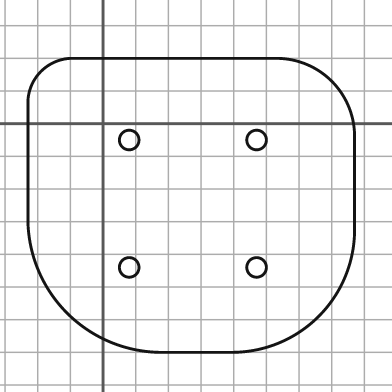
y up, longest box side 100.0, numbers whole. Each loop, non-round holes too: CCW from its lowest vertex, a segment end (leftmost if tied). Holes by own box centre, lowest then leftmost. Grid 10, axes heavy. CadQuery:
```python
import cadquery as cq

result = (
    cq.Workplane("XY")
    .moveTo(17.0, -70.0)
    .lineTo(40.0, -70.0)
    .threePointArc((66.0, -59.0), (77.0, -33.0))
    .lineTo(77.0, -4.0)
    .threePointArc((70.0, 13.0), (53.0, 20.0))
    .lineTo(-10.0, 20.0)
    .threePointArc((-19.0, 16.0), (-23.0, 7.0))
    .lineTo(-23.0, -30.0)
    .threePointArc((-11.0, -58.0), (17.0, -70.0))
    .close()
    .moveTo(8.0, -44.0)
    .circle(3.0)
    .moveTo(47.0, -44.0)
    .circle(3.0)
    .moveTo(8.0, -5.0)
    .circle(3.0)
    .moveTo(47.0, -5.0)
    .circle(3.0)
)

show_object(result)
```